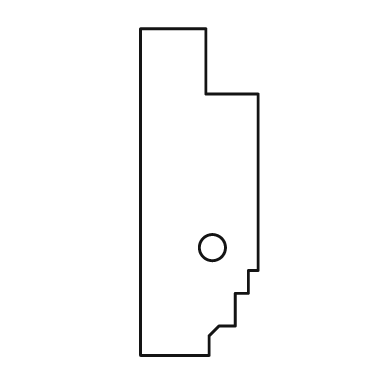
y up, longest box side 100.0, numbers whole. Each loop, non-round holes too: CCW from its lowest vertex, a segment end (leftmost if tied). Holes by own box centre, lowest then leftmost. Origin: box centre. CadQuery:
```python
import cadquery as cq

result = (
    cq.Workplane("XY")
    .moveTo(-18.0, -50.0)
    .lineTo(3.0, -50.0)
    .lineTo(3.0, -44.0)
    .lineTo(6.0, -41.0)
    .lineTo(11.0, -41.0)
    .lineTo(11.0, -31.0)
    .lineTo(15.0, -31.0)
    .lineTo(15.0, -24.0)
    .lineTo(18.0, -24.0)
    .lineTo(18.0, 30.0)
    .lineTo(2.0, 30.0)
    .lineTo(2.0, 50.0)
    .lineTo(-18.0, 50.0)
    .close()
    .moveTo(4.0, -17.0)
    .circle(4.0)
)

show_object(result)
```